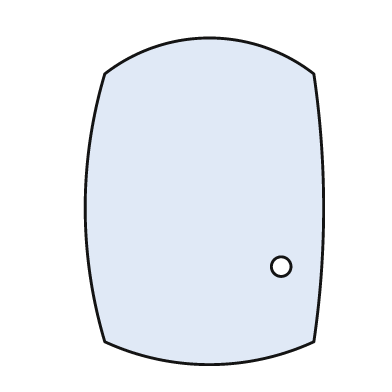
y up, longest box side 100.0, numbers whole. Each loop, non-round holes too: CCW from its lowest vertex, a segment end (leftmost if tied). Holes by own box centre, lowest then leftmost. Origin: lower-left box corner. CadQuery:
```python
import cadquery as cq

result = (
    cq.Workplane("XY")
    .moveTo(6.0, 7.0)
    .threePointArc((38.0, 0.0), (70.0, 7.0))
    .threePointArc((73.0, 48.0), (70.0, 89.0))
    .threePointArc((38.0, 100.0), (6.0, 89.0))
    .threePointArc((0.0, 48.0), (6.0, 7.0))
    .close()
    .moveTo(60.0, 30.0)
    .circle(3.0)
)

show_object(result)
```